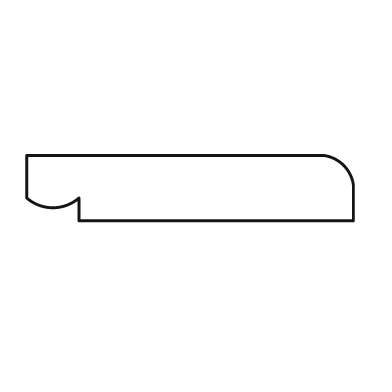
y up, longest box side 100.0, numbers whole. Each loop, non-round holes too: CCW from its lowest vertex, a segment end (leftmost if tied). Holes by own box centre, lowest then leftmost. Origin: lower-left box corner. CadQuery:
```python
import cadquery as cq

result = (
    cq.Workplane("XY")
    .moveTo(16.0, 0.0)
    .lineTo(100.0, 0.0)
    .lineTo(100.0, 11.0)
    .threePointArc((97.0, 17.0), (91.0, 20.0))
    .lineTo(0.0, 20.0)
    .lineTo(0.0, 7.0)
    .threePointArc((8.0, 4.0), (16.0, 7.0))
    .close()
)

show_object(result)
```